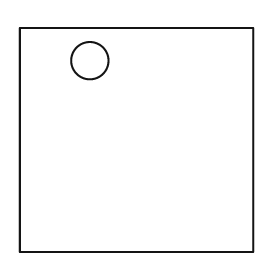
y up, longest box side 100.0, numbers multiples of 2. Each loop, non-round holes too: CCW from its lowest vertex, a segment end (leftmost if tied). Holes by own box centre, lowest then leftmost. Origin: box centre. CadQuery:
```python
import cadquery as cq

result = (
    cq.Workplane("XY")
    .moveTo(-50.0, -48.0)
    .lineTo(50.0, -48.0)
    .lineTo(50.0, 48.0)
    .lineTo(-50.0, 48.0)
    .close()
    .moveTo(-20.0, 34.0)
    .circle(8.0)
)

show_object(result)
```